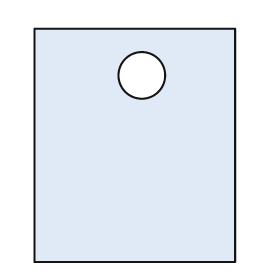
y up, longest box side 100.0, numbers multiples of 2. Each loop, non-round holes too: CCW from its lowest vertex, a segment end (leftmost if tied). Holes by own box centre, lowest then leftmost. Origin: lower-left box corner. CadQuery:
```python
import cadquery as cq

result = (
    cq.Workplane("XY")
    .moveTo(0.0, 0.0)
    .lineTo(86.0, 0.0)
    .lineTo(86.0, 100.0)
    .lineTo(0.0, 100.0)
    .close()
    .moveTo(46.0, 80.0)
    .circle(10.0)
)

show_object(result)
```